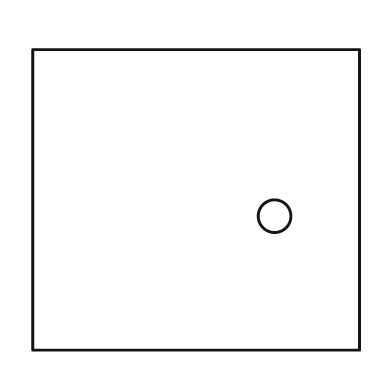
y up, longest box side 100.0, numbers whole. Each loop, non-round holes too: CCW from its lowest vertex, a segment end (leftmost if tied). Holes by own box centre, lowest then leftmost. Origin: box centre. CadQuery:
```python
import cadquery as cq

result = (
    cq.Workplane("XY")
    .moveTo(-50.0, -46.0)
    .lineTo(50.0, -46.0)
    .lineTo(50.0, 46.0)
    .lineTo(-50.0, 46.0)
    .close()
    .moveTo(24.0, -5.0)
    .circle(5.0)
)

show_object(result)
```